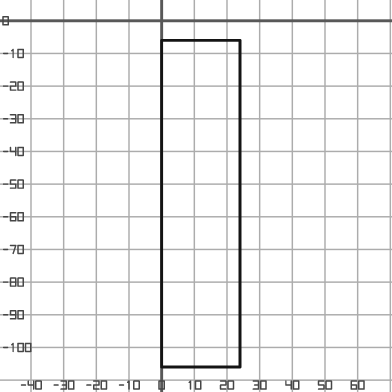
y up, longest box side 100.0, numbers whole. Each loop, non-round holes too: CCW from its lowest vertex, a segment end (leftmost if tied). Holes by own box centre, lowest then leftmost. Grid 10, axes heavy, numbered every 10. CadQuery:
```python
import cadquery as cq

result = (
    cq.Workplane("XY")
    .moveTo(0.0, -106.0)
    .lineTo(24.0, -106.0)
    .lineTo(24.0, -6.0)
    .lineTo(0.0, -6.0)
    .close()
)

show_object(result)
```